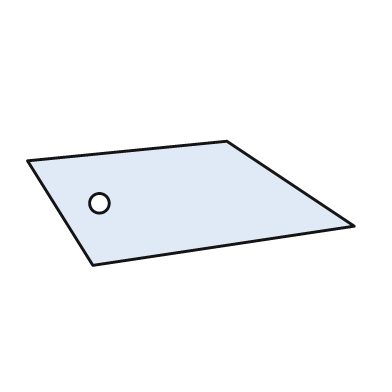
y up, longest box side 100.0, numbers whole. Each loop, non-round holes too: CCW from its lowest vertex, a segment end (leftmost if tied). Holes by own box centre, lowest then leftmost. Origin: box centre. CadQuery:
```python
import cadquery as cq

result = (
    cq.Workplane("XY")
    .moveTo(-30.0, -19.0)
    .lineTo(50.0, -7.0)
    .lineTo(11.0, 19.0)
    .lineTo(-50.0, 13.0)
    .close()
    .moveTo(-28.0, 0.0)
    .circle(3.0)
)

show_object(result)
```